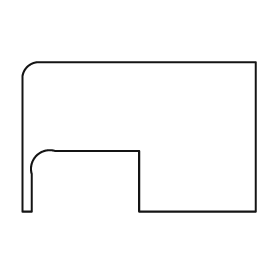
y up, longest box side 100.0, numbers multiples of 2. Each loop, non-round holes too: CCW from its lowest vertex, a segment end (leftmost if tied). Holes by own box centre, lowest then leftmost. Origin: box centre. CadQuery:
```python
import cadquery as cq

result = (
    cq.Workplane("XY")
    .moveTo(-50.0, -32.0)
    .lineTo(-46.0, -32.0)
    .lineTo(-46.0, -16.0)
    .threePointArc((-44.0, -8.0), (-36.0, -6.0))
    .lineTo(0.0, -6.0)
    .lineTo(0.0, -32.0)
    .lineTo(50.0, -32.0)
    .lineTo(50.0, 32.0)
    .lineTo(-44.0, 32.0)
    .threePointArc((-48.0, 30.0), (-50.0, 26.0))
    .close()
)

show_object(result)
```